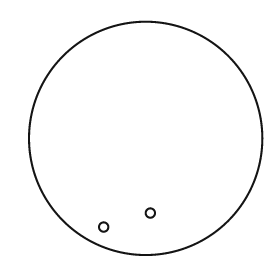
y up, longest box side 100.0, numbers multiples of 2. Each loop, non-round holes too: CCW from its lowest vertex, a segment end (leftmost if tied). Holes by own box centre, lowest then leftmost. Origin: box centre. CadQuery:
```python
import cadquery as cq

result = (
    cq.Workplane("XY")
    .moveTo(0.0, 0.0)
    .circle(50.0)
    .moveTo(-18.0, -38.0)
    .circle(2.0)
    .moveTo(2.0, -32.0)
    .circle(2.0)
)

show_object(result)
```